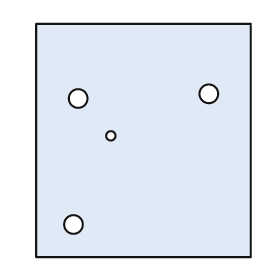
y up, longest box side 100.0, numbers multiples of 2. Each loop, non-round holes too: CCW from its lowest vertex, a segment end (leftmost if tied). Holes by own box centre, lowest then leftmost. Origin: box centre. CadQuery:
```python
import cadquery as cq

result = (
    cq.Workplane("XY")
    .moveTo(-46.0, -50.0)
    .lineTo(46.0, -50.0)
    .lineTo(46.0, 50.0)
    .lineTo(-46.0, 50.0)
    .close()
    .moveTo(-30.0, -36.0)
    .circle(4.0)
    .moveTo(-14.0, 2.0)
    .circle(2.0)
    .moveTo(-28.0, 18.0)
    .circle(4.0)
    .moveTo(28.0, 20.0)
    .circle(4.0)
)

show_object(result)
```